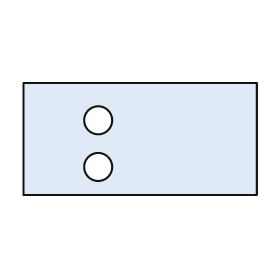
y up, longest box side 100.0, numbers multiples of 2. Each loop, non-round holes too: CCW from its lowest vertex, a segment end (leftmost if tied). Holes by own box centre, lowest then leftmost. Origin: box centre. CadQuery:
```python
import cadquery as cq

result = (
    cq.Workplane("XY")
    .moveTo(-50.0, -24.0)
    .lineTo(50.0, -24.0)
    .lineTo(50.0, 24.0)
    .lineTo(-50.0, 24.0)
    .close()
    .moveTo(-18.0, -12.0)
    .circle(6.0)
    .moveTo(-18.0, 8.0)
    .circle(6.0)
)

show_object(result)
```